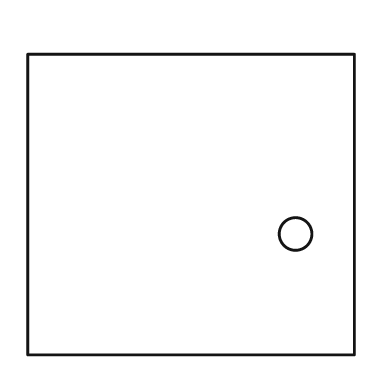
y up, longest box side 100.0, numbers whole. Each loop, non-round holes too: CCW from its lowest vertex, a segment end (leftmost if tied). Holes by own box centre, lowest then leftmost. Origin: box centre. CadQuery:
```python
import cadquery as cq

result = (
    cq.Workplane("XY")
    .moveTo(-50.0, -46.0)
    .lineTo(50.0, -46.0)
    .lineTo(50.0, 46.0)
    .lineTo(-50.0, 46.0)
    .close()
    .moveTo(32.0, -9.0)
    .circle(5.0)
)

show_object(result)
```